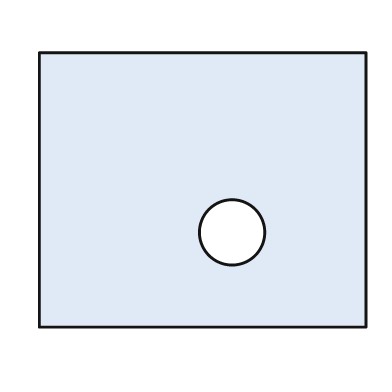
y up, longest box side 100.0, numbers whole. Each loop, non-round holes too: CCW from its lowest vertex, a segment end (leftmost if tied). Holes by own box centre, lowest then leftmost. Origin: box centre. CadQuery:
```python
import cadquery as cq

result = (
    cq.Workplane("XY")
    .moveTo(-50.0, -42.0)
    .lineTo(50.0, -42.0)
    .lineTo(50.0, 42.0)
    .lineTo(-50.0, 42.0)
    .close()
    .moveTo(9.0, -13.0)
    .circle(10.0)
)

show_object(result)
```